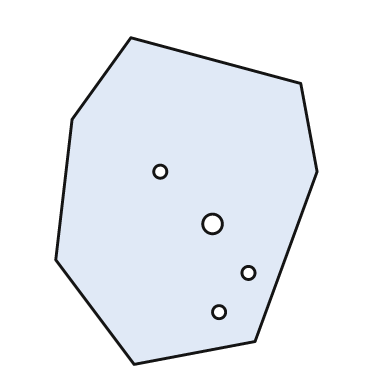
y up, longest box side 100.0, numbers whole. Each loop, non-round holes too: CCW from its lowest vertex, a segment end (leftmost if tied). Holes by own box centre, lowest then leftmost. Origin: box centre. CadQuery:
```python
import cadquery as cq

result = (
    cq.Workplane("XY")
    .moveTo(-16.0, -50.0)
    .lineTo(21.0, -43.0)
    .lineTo(40.0, 9.0)
    .lineTo(35.0, 36.0)
    .lineTo(-17.0, 50.0)
    .lineTo(-35.0, 25.0)
    .lineTo(-40.0, -18.0)
    .close()
    .moveTo(10.0, -34.0)
    .circle(2.0)
    .moveTo(19.0, -22.0)
    .circle(2.0)
    .moveTo(8.0, -7.0)
    .circle(3.0)
    .moveTo(-8.0, 9.0)
    .circle(2.0)
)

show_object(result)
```